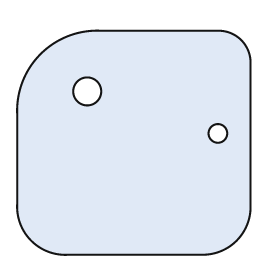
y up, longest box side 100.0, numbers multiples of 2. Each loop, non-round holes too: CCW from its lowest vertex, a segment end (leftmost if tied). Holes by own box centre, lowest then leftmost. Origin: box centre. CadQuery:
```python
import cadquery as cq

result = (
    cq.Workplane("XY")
    .moveTo(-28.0, -48.0)
    .lineTo(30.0, -48.0)
    .threePointArc((44.0, -42.0), (50.0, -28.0))
    .lineTo(50.0, 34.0)
    .threePointArc((46.0, 44.0), (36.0, 48.0))
    .lineTo(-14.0, 48.0)
    .threePointArc((-40.0, 38.0), (-50.0, 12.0))
    .lineTo(-50.0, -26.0)
    .threePointArc((-44.0, -42.0), (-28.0, -48.0))
    .close()
    .moveTo(36.0, 4.0)
    .circle(4.0)
    .moveTo(-20.0, 22.0)
    .circle(6.0)
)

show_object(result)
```